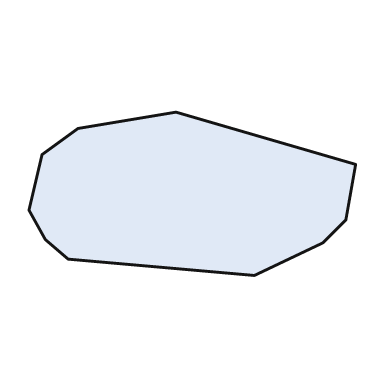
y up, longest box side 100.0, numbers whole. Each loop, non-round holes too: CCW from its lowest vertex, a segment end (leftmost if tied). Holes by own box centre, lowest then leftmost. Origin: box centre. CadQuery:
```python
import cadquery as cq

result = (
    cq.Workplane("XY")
    .moveTo(19.0, -25.0)
    .lineTo(40.0, -15.0)
    .lineTo(47.0, -8.0)
    .lineTo(50.0, 9.0)
    .lineTo(-5.0, 25.0)
    .lineTo(-35.0, 20.0)
    .lineTo(-46.0, 12.0)
    .lineTo(-50.0, -5.0)
    .lineTo(-45.0, -14.0)
    .lineTo(-38.0, -20.0)
    .close()
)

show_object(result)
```